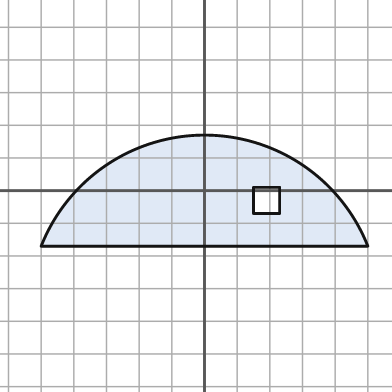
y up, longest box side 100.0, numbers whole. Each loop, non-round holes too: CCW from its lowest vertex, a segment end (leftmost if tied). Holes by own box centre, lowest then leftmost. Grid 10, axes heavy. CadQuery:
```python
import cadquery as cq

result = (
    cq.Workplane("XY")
    .moveTo(-50.0, -17.0)
    .lineTo(50.0, -17.0)
    .threePointArc((0.0, 17.0), (-50.0, -17.0))
    .close()
    .moveTo(15.0, -7.0)
    .lineTo(23.0, -7.0)
    .lineTo(23.0, 1.0)
    .lineTo(15.0, 1.0)
    .close()
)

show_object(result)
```